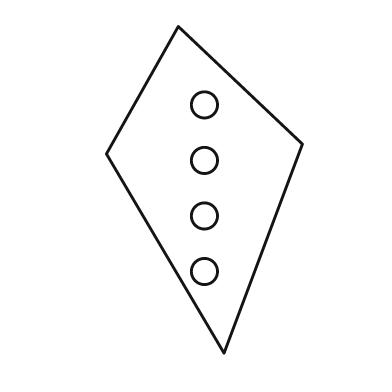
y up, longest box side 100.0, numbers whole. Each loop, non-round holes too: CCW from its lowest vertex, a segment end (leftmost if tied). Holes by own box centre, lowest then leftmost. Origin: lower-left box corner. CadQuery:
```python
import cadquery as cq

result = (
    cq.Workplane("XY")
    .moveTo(36.0, 0.0)
    .lineTo(60.0, 64.0)
    .lineTo(22.0, 100.0)
    .lineTo(0.0, 61.0)
    .close()
    .moveTo(30.0, 25.0)
    .circle(4.0)
    .moveTo(30.0, 42.0)
    .circle(4.0)
    .moveTo(30.0, 59.0)
    .circle(4.0)
    .moveTo(30.0, 76.0)
    .circle(4.0)
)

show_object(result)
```